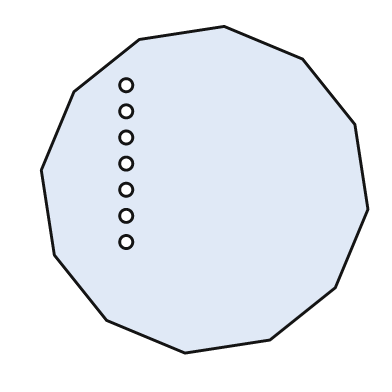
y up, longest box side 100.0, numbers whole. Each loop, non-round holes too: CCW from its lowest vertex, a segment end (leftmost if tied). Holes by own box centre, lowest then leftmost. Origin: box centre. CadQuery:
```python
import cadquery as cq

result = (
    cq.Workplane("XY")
    .moveTo(-6.0, -50.0)
    .lineTo(20.0, -46.0)
    .lineTo(40.0, -30.0)
    .lineTo(50.0, -6.0)
    .lineTo(46.0, 20.0)
    .lineTo(30.0, 40.0)
    .lineTo(6.0, 50.0)
    .lineTo(-20.0, 46.0)
    .lineTo(-40.0, 30.0)
    .lineTo(-50.0, 6.0)
    .lineTo(-46.0, -20.0)
    .lineTo(-30.0, -40.0)
    .close()
    .moveTo(-24.0, -16.0)
    .circle(2.0)
    .moveTo(-24.0, -8.0)
    .circle(2.0)
    .moveTo(-24.0, 0.0)
    .circle(2.0)
    .moveTo(-24.0, 8.0)
    .circle(2.0)
    .moveTo(-24.0, 16.0)
    .circle(2.0)
    .moveTo(-24.0, 24.0)
    .circle(2.0)
    .moveTo(-24.0, 32.0)
    .circle(2.0)
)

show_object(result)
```